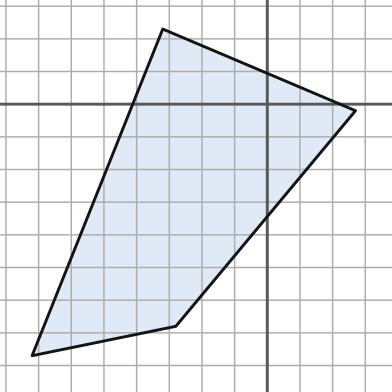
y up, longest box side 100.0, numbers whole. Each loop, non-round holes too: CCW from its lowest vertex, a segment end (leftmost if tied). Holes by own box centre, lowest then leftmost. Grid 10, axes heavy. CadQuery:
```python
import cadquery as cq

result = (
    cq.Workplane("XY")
    .moveTo(-72.0, -77.0)
    .lineTo(-28.0, -68.0)
    .lineTo(27.0, -2.0)
    .lineTo(-32.0, 23.0)
    .close()
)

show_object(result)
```